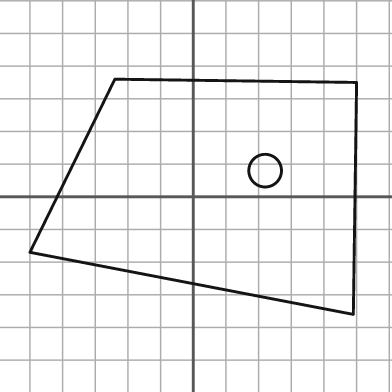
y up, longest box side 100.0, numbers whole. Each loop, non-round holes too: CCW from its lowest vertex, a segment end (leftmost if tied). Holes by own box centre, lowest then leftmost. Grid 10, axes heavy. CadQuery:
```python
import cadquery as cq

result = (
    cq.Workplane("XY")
    .moveTo(49.0, -36.0)
    .lineTo(50.0, 35.0)
    .lineTo(-24.0, 36.0)
    .lineTo(-50.0, -17.0)
    .close()
    .moveTo(22.0, 8.0)
    .circle(5.0)
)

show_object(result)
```